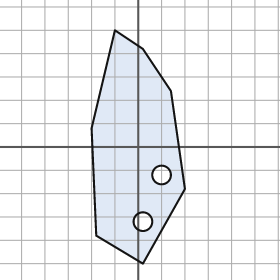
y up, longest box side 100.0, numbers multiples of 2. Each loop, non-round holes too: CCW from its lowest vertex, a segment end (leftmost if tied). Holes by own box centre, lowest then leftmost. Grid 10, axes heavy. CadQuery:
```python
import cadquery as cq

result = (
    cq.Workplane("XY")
    .moveTo(2.0, -50.0)
    .lineTo(20.0, -18.0)
    .lineTo(14.0, 24.0)
    .lineTo(2.0, 42.0)
    .lineTo(-10.0, 50.0)
    .lineTo(-20.0, 8.0)
    .lineTo(-18.0, -38.0)
    .close()
    .moveTo(2.0, -32.0)
    .circle(4.0)
    .moveTo(10.0, -12.0)
    .circle(4.0)
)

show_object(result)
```